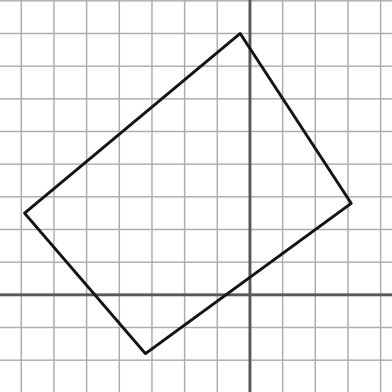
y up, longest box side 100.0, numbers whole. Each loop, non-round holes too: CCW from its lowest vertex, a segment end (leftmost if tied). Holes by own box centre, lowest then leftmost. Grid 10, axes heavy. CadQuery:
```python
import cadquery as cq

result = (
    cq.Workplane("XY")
    .moveTo(-32.0, -18.0)
    .lineTo(31.0, 28.0)
    .lineTo(-3.0, 80.0)
    .lineTo(-69.0, 25.0)
    .close()
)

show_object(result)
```